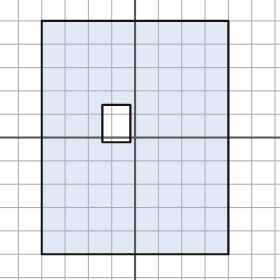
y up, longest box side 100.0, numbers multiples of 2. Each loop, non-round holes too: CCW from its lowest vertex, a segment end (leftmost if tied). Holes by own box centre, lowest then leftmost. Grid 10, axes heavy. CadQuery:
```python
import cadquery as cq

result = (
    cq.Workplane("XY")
    .moveTo(-40.0, -50.0)
    .lineTo(40.0, -50.0)
    .lineTo(40.0, 50.0)
    .lineTo(-40.0, 50.0)
    .close()
    .moveTo(-14.0, -2.0)
    .lineTo(-2.0, -2.0)
    .lineTo(-2.0, 14.0)
    .lineTo(-14.0, 14.0)
    .close()
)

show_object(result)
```